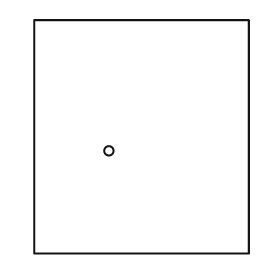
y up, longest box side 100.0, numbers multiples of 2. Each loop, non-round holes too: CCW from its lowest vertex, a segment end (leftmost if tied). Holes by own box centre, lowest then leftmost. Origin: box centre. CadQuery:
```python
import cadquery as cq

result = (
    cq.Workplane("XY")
    .moveTo(-46.0, -50.0)
    .lineTo(46.0, -50.0)
    .lineTo(46.0, 50.0)
    .lineTo(-46.0, 50.0)
    .close()
    .moveTo(-14.0, -6.0)
    .circle(2.0)
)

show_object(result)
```